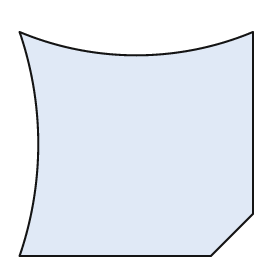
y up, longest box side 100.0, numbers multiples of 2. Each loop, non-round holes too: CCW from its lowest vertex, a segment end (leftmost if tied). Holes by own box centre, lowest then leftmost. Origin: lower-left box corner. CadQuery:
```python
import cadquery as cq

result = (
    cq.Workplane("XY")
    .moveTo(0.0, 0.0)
    .lineTo(82.0, 0.0)
    .lineTo(100.0, 18.0)
    .lineTo(100.0, 96.0)
    .threePointArc((50.0, 86.0), (0.0, 96.0))
    .threePointArc((8.0, 48.0), (0.0, 0.0))
    .close()
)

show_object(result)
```